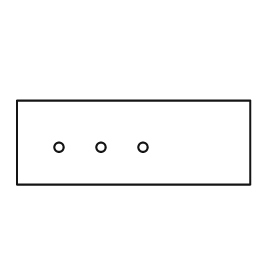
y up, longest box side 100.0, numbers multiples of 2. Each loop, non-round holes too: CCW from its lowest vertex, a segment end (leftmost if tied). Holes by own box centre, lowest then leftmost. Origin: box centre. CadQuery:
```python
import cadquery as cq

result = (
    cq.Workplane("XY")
    .moveTo(-50.0, -18.0)
    .lineTo(50.0, -18.0)
    .lineTo(50.0, 18.0)
    .lineTo(-50.0, 18.0)
    .close()
    .moveTo(-32.0, -2.0)
    .circle(2.0)
    .moveTo(-14.0, -2.0)
    .circle(2.0)
    .moveTo(4.0, -2.0)
    .circle(2.0)
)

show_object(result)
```